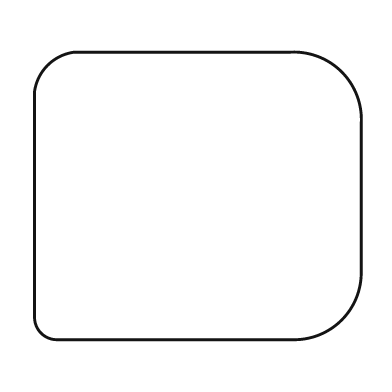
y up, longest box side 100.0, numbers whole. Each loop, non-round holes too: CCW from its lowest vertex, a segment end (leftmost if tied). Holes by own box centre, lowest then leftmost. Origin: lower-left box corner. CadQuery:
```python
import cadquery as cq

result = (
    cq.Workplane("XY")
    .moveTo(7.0, 0.0)
    .lineTo(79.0, 0.0)
    .threePointArc((94.0, 6.0), (100.0, 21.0))
    .lineTo(100.0, 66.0)
    .threePointArc((94.0, 82.0), (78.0, 88.0))
    .lineTo(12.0, 88.0)
    .threePointArc((4.0, 84.0), (0.0, 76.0))
    .lineTo(0.0, 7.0)
    .threePointArc((2.0, 2.0), (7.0, 0.0))
    .close()
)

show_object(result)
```